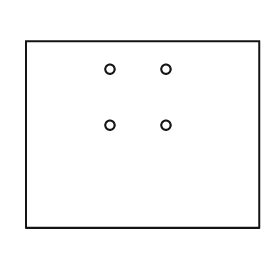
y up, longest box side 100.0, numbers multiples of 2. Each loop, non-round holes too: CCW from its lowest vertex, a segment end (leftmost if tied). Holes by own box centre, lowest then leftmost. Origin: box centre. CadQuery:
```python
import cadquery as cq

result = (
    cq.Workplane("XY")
    .moveTo(-50.0, -40.0)
    .lineTo(50.0, -40.0)
    .lineTo(50.0, 40.0)
    .lineTo(-50.0, 40.0)
    .close()
    .moveTo(-14.0, 4.0)
    .circle(2.0)
    .moveTo(10.0, 4.0)
    .circle(2.0)
    .moveTo(-14.0, 28.0)
    .circle(2.0)
    .moveTo(10.0, 28.0)
    .circle(2.0)
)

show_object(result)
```